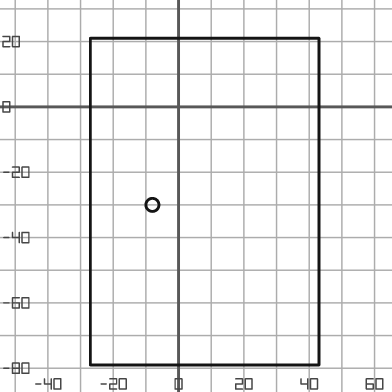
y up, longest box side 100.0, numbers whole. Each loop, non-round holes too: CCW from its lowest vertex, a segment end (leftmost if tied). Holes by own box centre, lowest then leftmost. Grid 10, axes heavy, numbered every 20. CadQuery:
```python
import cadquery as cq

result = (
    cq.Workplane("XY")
    .moveTo(-27.0, -79.0)
    .lineTo(43.0, -79.0)
    .lineTo(43.0, 21.0)
    .lineTo(-27.0, 21.0)
    .close()
    .moveTo(-8.0, -30.0)
    .circle(2.0)
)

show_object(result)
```